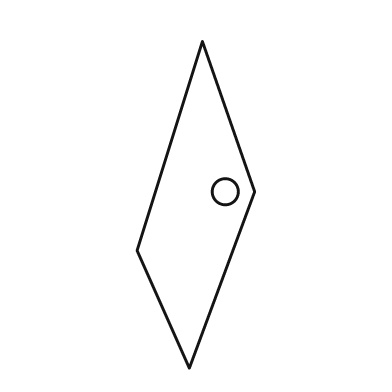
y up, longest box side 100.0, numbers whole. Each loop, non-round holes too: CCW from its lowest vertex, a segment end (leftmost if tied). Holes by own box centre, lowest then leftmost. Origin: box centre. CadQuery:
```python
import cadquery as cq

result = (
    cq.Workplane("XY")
    .moveTo(-2.0, -50.0)
    .lineTo(18.0, 4.0)
    .lineTo(2.0, 50.0)
    .lineTo(-18.0, -14.0)
    .close()
    .moveTo(9.0, 4.0)
    .circle(4.0)
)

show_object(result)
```